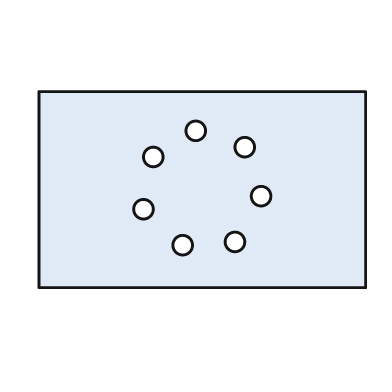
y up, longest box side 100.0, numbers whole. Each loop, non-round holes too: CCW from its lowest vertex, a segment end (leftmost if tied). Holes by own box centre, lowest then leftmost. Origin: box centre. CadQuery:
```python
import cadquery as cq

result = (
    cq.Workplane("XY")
    .moveTo(-50.0, -30.0)
    .lineTo(50.0, -30.0)
    .lineTo(50.0, 30.0)
    .lineTo(-50.0, 30.0)
    .close()
    .moveTo(-6.0, -17.0)
    .circle(3.0)
    .moveTo(10.0, -16.0)
    .circle(3.0)
    .moveTo(-18.0, -6.0)
    .circle(3.0)
    .moveTo(18.0, -2.0)
    .circle(3.0)
    .moveTo(-15.0, 10.0)
    .circle(3.0)
    .moveTo(13.0, 13.0)
    .circle(3.0)
    .moveTo(-2.0, 18.0)
    .circle(3.0)
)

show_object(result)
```